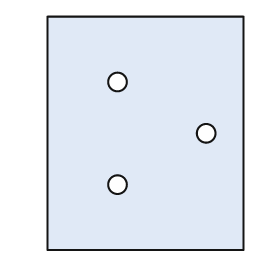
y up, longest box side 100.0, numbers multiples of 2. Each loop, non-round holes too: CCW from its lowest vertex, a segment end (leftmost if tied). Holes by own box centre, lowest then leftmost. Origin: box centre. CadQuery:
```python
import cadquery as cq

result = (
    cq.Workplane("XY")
    .moveTo(-42.0, -50.0)
    .lineTo(42.0, -50.0)
    .lineTo(42.0, 50.0)
    .lineTo(-42.0, 50.0)
    .close()
    .moveTo(-12.0, -22.0)
    .circle(4.0)
    .moveTo(26.0, 0.0)
    .circle(4.0)
    .moveTo(-12.0, 22.0)
    .circle(4.0)
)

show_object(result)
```